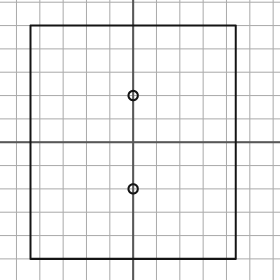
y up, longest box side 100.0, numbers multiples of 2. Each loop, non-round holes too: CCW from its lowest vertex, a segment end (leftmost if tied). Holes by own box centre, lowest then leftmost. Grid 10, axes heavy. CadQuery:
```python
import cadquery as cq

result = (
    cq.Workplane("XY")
    .moveTo(-44.0, -50.0)
    .lineTo(44.0, -50.0)
    .lineTo(44.0, 50.0)
    .lineTo(-44.0, 50.0)
    .close()
    .moveTo(0.0, -20.0)
    .circle(2.0)
    .moveTo(0.0, 20.0)
    .circle(2.0)
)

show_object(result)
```